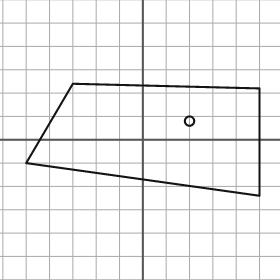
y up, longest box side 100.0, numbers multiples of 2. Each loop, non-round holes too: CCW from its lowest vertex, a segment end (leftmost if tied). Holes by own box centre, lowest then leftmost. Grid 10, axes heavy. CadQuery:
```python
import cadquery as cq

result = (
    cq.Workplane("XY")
    .moveTo(50.0, -24.0)
    .lineTo(50.0, 22.0)
    .lineTo(-30.0, 24.0)
    .lineTo(-50.0, -10.0)
    .close()
    .moveTo(20.0, 8.0)
    .circle(2.0)
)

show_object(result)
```